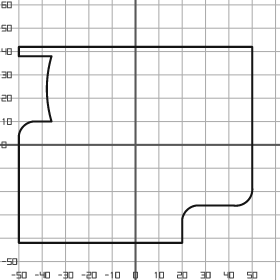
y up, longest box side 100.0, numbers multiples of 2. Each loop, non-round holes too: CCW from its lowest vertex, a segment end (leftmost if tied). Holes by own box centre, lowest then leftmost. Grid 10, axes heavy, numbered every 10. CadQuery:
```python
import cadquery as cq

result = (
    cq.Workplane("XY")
    .moveTo(-50.0, -42.0)
    .lineTo(20.0, -42.0)
    .lineTo(20.0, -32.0)
    .threePointArc((22.0, -28.0), (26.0, -26.0))
    .lineTo(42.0, -26.0)
    .threePointArc((48.0, -24.0), (50.0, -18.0))
    .lineTo(50.0, 42.0)
    .lineTo(-50.0, 42.0)
    .lineTo(-50.0, 38.0)
    .lineTo(-36.0, 38.0)
    .threePointArc((-38.0, 24.0), (-36.0, 10.0))
    .lineTo(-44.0, 10.0)
    .threePointArc((-48.0, 8.0), (-50.0, 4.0))
    .close()
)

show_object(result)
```